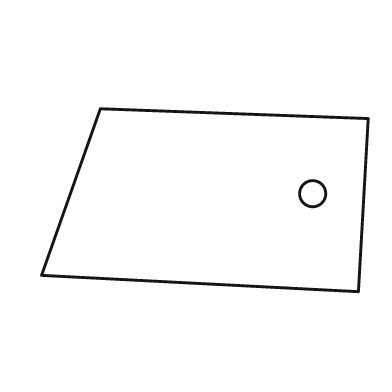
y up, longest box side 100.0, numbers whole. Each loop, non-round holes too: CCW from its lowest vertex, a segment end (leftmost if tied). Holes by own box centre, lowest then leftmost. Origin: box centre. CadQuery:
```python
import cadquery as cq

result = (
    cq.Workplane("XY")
    .moveTo(47.0, -28.0)
    .lineTo(50.0, 25.0)
    .lineTo(-32.0, 28.0)
    .lineTo(-50.0, -23.0)
    .close()
    .moveTo(33.0, 2.0)
    .circle(4.0)
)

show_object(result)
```